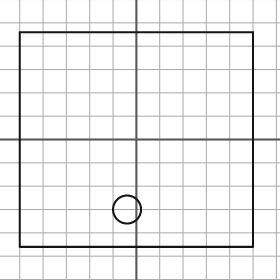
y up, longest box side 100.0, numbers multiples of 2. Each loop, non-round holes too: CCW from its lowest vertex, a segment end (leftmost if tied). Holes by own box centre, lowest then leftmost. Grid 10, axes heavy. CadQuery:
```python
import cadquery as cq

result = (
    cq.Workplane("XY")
    .moveTo(-50.0, -46.0)
    .lineTo(50.0, -46.0)
    .lineTo(50.0, 46.0)
    .lineTo(-50.0, 46.0)
    .close()
    .moveTo(-4.0, -30.0)
    .circle(6.0)
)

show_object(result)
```